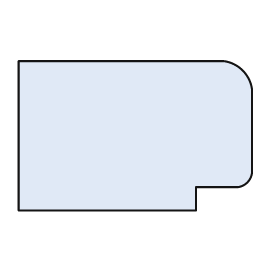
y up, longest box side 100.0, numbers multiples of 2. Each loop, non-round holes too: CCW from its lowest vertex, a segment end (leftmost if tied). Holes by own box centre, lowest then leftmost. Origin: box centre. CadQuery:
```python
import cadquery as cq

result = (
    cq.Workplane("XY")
    .moveTo(-50.0, -32.0)
    .lineTo(26.0, -32.0)
    .lineTo(26.0, -22.0)
    .lineTo(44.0, -22.0)
    .threePointArc((48.0, -20.0), (50.0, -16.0))
    .lineTo(50.0, 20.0)
    .threePointArc((46.0, 28.0), (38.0, 32.0))
    .lineTo(-50.0, 32.0)
    .close()
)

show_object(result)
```